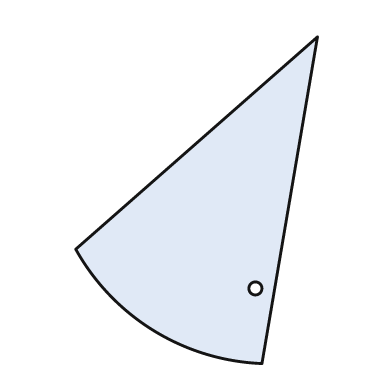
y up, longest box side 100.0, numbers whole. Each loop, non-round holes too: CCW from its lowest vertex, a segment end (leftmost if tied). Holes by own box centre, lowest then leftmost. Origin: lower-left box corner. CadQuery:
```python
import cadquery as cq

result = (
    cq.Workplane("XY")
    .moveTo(57.0, 0.0)
    .lineTo(74.0, 100.0)
    .lineTo(0.0, 35.0)
    .threePointArc((24.0, 10.0), (57.0, 0.0))
    .close()
    .moveTo(55.0, 23.0)
    .circle(2.0)
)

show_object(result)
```